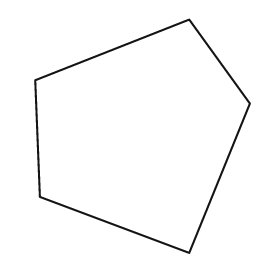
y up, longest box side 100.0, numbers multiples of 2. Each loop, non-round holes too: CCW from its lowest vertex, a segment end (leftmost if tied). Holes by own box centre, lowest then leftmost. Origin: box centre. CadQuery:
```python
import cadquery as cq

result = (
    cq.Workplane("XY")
    .moveTo(20.0, -50.0)
    .lineTo(46.0, 14.0)
    .lineTo(20.0, 50.0)
    .lineTo(-46.0, 24.0)
    .lineTo(-44.0, -26.0)
    .close()
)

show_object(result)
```